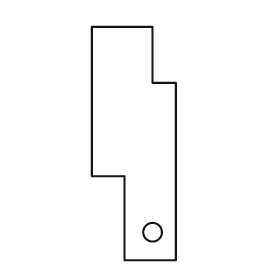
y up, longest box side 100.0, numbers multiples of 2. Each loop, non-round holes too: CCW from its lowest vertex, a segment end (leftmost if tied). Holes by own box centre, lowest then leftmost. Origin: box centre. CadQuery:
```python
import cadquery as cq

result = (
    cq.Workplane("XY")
    .moveTo(-4.0, -50.0)
    .lineTo(18.0, -50.0)
    .lineTo(18.0, 26.0)
    .lineTo(8.0, 26.0)
    .lineTo(8.0, 50.0)
    .lineTo(-18.0, 50.0)
    .lineTo(-18.0, -14.0)
    .lineTo(-4.0, -14.0)
    .close()
    .moveTo(8.0, -38.0)
    .circle(4.0)
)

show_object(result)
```